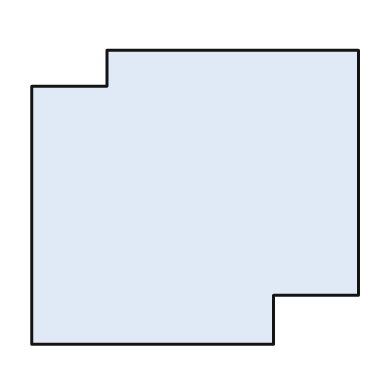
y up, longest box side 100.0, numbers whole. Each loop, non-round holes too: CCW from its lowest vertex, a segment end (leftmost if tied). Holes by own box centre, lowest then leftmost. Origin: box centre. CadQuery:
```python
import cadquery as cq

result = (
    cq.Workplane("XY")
    .moveTo(-50.0, -45.0)
    .lineTo(24.0, -45.0)
    .lineTo(24.0, -30.0)
    .lineTo(50.0, -30.0)
    .lineTo(50.0, 45.0)
    .lineTo(-27.0, 45.0)
    .lineTo(-27.0, 34.0)
    .lineTo(-50.0, 34.0)
    .close()
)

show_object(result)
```